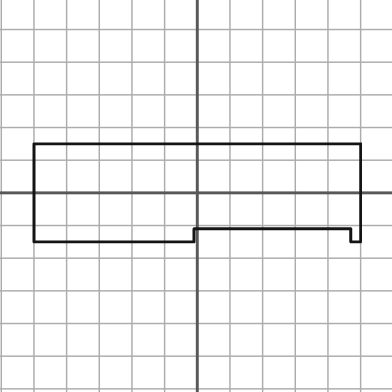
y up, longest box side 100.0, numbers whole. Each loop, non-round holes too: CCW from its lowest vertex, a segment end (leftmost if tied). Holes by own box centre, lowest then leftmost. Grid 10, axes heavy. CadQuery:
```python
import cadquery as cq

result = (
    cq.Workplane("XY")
    .moveTo(-50.0, -15.0)
    .lineTo(-1.0, -15.0)
    .lineTo(-1.0, -11.0)
    .lineTo(47.0, -11.0)
    .lineTo(47.0, -15.0)
    .lineTo(50.0, -15.0)
    .lineTo(50.0, 15.0)
    .lineTo(-50.0, 15.0)
    .close()
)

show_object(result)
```